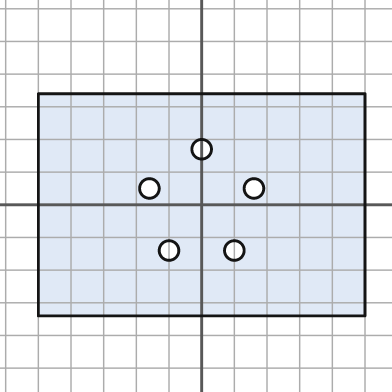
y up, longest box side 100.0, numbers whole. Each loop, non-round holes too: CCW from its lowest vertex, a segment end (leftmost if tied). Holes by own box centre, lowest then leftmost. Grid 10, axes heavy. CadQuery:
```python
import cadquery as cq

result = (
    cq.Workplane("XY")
    .moveTo(-50.0, -34.0)
    .lineTo(50.0, -34.0)
    .lineTo(50.0, 34.0)
    .lineTo(-50.0, 34.0)
    .close()
    .moveTo(-10.0, -14.0)
    .circle(3.0)
    .moveTo(10.0, -14.0)
    .circle(3.0)
    .moveTo(-16.0, 5.0)
    .circle(3.0)
    .moveTo(16.0, 5.0)
    .circle(3.0)
    .moveTo(0.0, 17.0)
    .circle(3.0)
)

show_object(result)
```